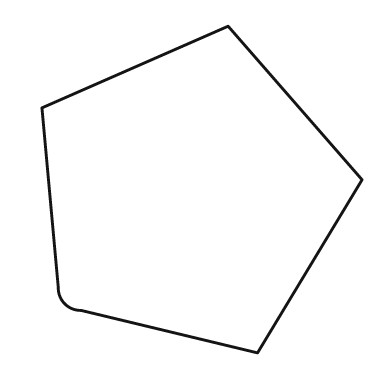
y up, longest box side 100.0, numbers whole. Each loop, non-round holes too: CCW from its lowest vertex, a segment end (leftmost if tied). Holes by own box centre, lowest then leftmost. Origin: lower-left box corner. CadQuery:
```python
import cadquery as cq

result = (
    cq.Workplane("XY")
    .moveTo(66.0, 0.0)
    .lineTo(98.0, 53.0)
    .lineTo(57.0, 100.0)
    .lineTo(0.0, 75.0)
    .lineTo(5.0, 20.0)
    .threePointArc((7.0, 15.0), (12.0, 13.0))
    .close()
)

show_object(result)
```